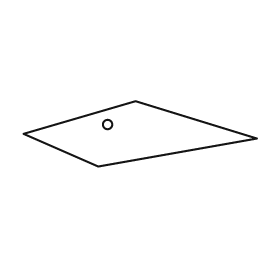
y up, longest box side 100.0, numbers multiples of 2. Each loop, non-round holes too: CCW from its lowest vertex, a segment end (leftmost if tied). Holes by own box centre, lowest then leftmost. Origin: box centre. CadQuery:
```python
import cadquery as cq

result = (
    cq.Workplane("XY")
    .moveTo(-18.0, -14.0)
    .lineTo(50.0, -2.0)
    .lineTo(-2.0, 14.0)
    .lineTo(-50.0, 0.0)
    .close()
    .moveTo(-14.0, 4.0)
    .circle(2.0)
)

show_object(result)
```